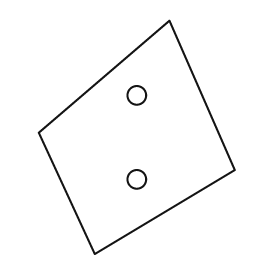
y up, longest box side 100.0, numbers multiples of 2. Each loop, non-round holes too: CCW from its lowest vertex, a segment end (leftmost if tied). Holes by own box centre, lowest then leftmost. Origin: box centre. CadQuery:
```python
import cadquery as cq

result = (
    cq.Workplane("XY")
    .moveTo(-18.0, -50.0)
    .lineTo(42.0, -14.0)
    .lineTo(14.0, 50.0)
    .lineTo(-42.0, 2.0)
    .close()
    .moveTo(0.0, -18.0)
    .circle(4.0)
    .moveTo(0.0, 18.0)
    .circle(4.0)
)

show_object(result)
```